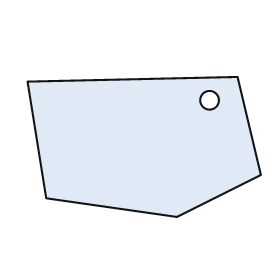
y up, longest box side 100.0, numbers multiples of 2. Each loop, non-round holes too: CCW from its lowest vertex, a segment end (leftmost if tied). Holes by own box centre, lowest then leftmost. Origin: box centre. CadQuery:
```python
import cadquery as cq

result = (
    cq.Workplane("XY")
    .moveTo(14.0, -30.0)
    .lineTo(50.0, -12.0)
    .lineTo(40.0, 30.0)
    .lineTo(-50.0, 28.0)
    .lineTo(-42.0, -22.0)
    .close()
    .moveTo(28.0, 20.0)
    .circle(4.0)
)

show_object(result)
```